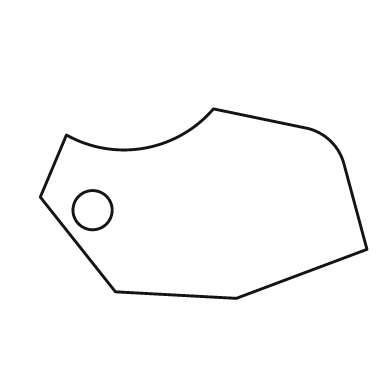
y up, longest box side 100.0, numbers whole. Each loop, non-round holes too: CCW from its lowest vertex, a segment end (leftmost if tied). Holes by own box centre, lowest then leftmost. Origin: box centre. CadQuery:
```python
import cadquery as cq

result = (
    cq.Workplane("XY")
    .moveTo(10.0, -29.0)
    .lineTo(50.0, -14.0)
    .lineTo(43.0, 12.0)
    .threePointArc((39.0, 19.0), (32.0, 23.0))
    .lineTo(3.0, 29.0)
    .threePointArc((-18.0, 17.0), (-42.0, 21.0))
    .lineTo(-50.0, 2.0)
    .lineTo(-27.0, -27.0)
    .close()
    .moveTo(-34.0, -2.0)
    .circle(6.0)
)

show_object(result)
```